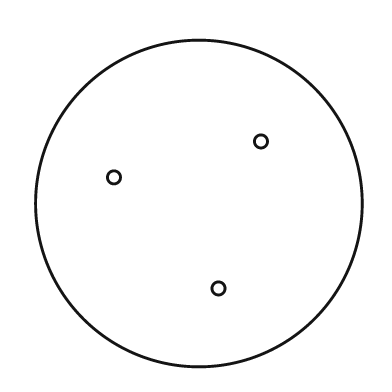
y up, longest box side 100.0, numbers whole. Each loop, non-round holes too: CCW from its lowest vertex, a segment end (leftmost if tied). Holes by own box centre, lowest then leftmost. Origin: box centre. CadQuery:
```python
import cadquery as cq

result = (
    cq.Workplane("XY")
    .moveTo(0.0, 0.0)
    .circle(50.0)
    .moveTo(6.0, -26.0)
    .circle(2.0)
    .moveTo(-26.0, 8.0)
    .circle(2.0)
    .moveTo(19.0, 19.0)
    .circle(2.0)
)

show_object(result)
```